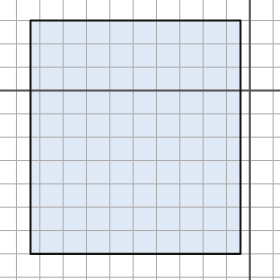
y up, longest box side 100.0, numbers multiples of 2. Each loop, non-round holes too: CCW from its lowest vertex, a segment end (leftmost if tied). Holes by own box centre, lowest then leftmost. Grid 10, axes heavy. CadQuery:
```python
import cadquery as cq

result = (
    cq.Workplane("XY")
    .moveTo(-94.0, -70.0)
    .lineTo(-4.0, -70.0)
    .lineTo(-4.0, 30.0)
    .lineTo(-94.0, 30.0)
    .close()
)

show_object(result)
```